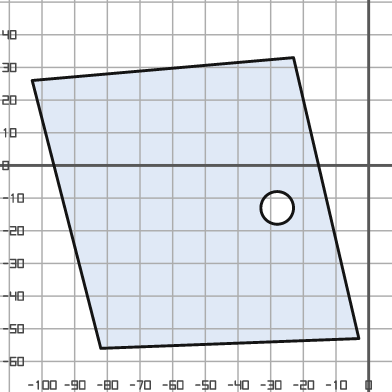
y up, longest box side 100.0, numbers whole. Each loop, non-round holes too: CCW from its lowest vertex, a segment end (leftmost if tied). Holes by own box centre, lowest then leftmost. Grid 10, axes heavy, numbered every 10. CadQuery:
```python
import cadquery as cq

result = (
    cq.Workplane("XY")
    .moveTo(-82.0, -56.0)
    .lineTo(-3.0, -53.0)
    .lineTo(-23.0, 33.0)
    .lineTo(-103.0, 26.0)
    .close()
    .moveTo(-28.0, -13.0)
    .circle(5.0)
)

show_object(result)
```